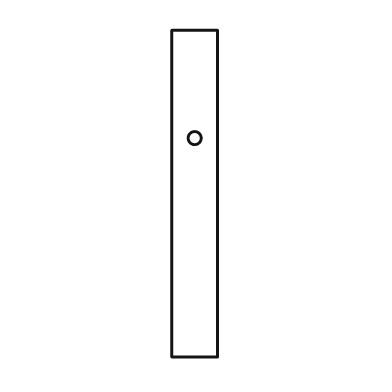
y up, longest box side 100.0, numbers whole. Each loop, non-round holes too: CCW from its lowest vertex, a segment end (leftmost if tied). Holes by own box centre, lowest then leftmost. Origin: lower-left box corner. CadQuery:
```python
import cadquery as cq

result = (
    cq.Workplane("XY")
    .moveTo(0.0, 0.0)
    .lineTo(14.0, 0.0)
    .lineTo(14.0, 100.0)
    .lineTo(0.0, 100.0)
    .close()
    .moveTo(7.0, 67.0)
    .circle(2.0)
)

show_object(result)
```